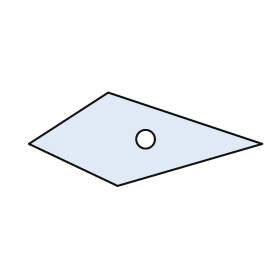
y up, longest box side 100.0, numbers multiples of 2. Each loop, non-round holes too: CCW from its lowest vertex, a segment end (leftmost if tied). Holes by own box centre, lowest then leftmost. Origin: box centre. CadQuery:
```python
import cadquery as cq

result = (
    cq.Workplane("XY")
    .moveTo(-12.0, -20.0)
    .lineTo(50.0, -2.0)
    .lineTo(-16.0, 20.0)
    .lineTo(-50.0, -2.0)
    .close()
    .moveTo(0.0, 0.0)
    .circle(4.0)
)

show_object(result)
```